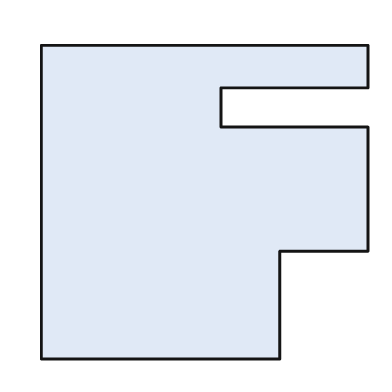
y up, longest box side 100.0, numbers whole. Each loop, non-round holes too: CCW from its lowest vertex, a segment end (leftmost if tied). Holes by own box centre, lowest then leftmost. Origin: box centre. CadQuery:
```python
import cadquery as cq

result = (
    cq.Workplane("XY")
    .moveTo(-50.0, -48.0)
    .lineTo(23.0, -48.0)
    .lineTo(23.0, -15.0)
    .lineTo(50.0, -15.0)
    .lineTo(50.0, 23.0)
    .lineTo(5.0, 23.0)
    .lineTo(5.0, 35.0)
    .lineTo(50.0, 35.0)
    .lineTo(50.0, 48.0)
    .lineTo(-50.0, 48.0)
    .close()
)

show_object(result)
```